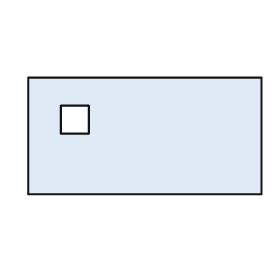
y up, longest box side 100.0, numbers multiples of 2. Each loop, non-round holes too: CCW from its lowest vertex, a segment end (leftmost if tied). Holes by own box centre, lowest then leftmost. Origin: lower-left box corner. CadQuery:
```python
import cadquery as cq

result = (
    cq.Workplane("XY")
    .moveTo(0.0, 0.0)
    .lineTo(100.0, 0.0)
    .lineTo(100.0, 50.0)
    .lineTo(0.0, 50.0)
    .close()
    .moveTo(14.0, 26.0)
    .lineTo(26.0, 26.0)
    .lineTo(26.0, 38.0)
    .lineTo(14.0, 38.0)
    .close()
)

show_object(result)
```